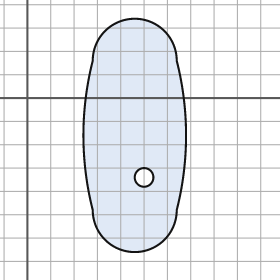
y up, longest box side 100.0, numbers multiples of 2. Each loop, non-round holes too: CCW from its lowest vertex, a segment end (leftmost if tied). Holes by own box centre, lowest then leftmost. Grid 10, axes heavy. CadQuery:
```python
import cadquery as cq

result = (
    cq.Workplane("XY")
    .moveTo(28.0, -48.0)
    .threePointArc((46.0, -66.0), (64.0, -48.0))
    .threePointArc((68.0, -16.0), (64.0, 16.0))
    .threePointArc((46.0, 34.0), (28.0, 16.0))
    .threePointArc((24.0, -16.0), (28.0, -48.0))
    .close()
    .moveTo(50.0, -34.0)
    .circle(4.0)
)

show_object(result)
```